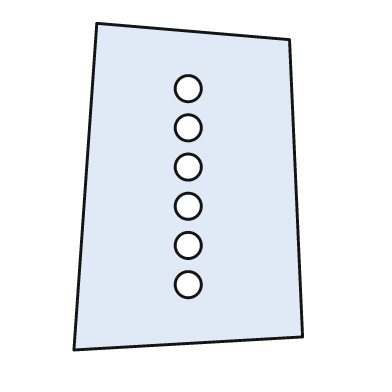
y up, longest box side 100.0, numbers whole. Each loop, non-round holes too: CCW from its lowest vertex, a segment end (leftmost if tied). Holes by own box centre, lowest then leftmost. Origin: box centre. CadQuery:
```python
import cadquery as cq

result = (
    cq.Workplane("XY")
    .moveTo(-35.0, -50.0)
    .lineTo(35.0, -46.0)
    .lineTo(31.0, 45.0)
    .lineTo(-28.0, 50.0)
    .close()
    .moveTo(0.0, -30.0)
    .circle(4.0)
    .moveTo(0.0, -18.0)
    .circle(4.0)
    .moveTo(0.0, -6.0)
    .circle(4.0)
    .moveTo(0.0, 6.0)
    .circle(4.0)
    .moveTo(0.0, 18.0)
    .circle(4.0)
    .moveTo(0.0, 30.0)
    .circle(4.0)
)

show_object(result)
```